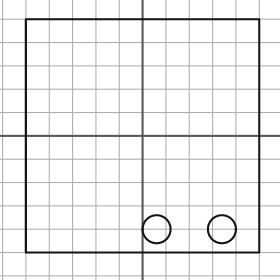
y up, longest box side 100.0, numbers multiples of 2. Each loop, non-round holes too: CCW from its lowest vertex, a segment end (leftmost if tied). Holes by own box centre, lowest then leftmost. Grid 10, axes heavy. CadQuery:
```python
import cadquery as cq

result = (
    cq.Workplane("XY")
    .moveTo(-50.0, -50.0)
    .lineTo(50.0, -50.0)
    .lineTo(50.0, 50.0)
    .lineTo(-50.0, 50.0)
    .close()
    .moveTo(6.0, -40.0)
    .circle(6.0)
    .moveTo(34.0, -40.0)
    .circle(6.0)
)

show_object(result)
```